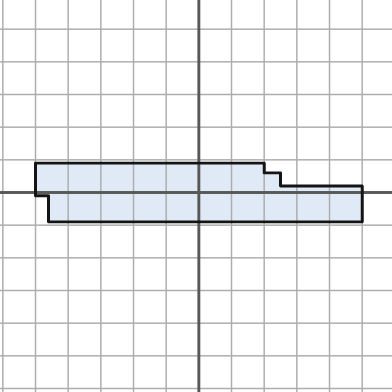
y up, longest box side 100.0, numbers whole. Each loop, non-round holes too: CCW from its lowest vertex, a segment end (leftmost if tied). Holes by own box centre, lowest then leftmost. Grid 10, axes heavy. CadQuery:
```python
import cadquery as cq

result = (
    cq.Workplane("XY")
    .moveTo(-46.0, -9.0)
    .lineTo(50.0, -9.0)
    .lineTo(50.0, 2.0)
    .lineTo(25.0, 2.0)
    .lineTo(25.0, 6.0)
    .lineTo(20.0, 6.0)
    .lineTo(20.0, 9.0)
    .lineTo(-50.0, 9.0)
    .lineTo(-50.0, -1.0)
    .lineTo(-46.0, -1.0)
    .close()
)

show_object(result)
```